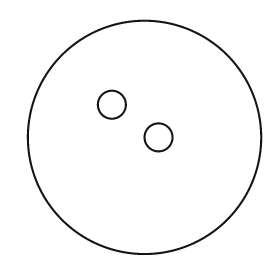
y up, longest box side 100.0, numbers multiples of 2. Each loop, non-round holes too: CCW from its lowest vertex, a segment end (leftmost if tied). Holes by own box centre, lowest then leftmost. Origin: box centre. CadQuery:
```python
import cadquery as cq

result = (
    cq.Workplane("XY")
    .moveTo(0.0, 0.0)
    .circle(50.0)
    .moveTo(6.0, 0.0)
    .circle(6.0)
    .moveTo(-14.0, 14.0)
    .circle(6.0)
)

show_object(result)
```